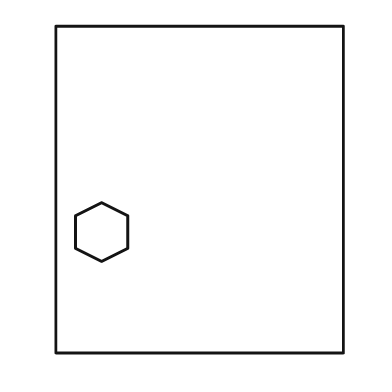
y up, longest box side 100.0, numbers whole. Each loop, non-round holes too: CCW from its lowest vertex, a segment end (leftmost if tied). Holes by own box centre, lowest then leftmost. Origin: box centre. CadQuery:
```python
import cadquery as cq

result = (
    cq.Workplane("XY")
    .moveTo(-44.0, -50.0)
    .lineTo(44.0, -50.0)
    .lineTo(44.0, 50.0)
    .lineTo(-44.0, 50.0)
    .close()
    .moveTo(-30.0, -22.0)
    .lineTo(-22.0, -18.0)
    .lineTo(-22.0, -8.0)
    .lineTo(-30.0, -4.0)
    .lineTo(-38.0, -8.0)
    .lineTo(-38.0, -18.0)
    .close()
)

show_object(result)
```